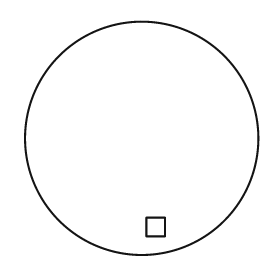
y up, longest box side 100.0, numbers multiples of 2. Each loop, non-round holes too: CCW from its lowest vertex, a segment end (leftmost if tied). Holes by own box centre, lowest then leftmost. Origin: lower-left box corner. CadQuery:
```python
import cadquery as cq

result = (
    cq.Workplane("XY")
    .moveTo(50.0, 50.0)
    .circle(50.0)
    .moveTo(52.0, 8.0)
    .lineTo(60.0, 8.0)
    .lineTo(60.0, 16.0)
    .lineTo(52.0, 16.0)
    .close()
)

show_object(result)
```